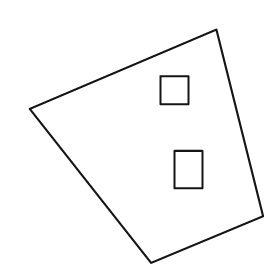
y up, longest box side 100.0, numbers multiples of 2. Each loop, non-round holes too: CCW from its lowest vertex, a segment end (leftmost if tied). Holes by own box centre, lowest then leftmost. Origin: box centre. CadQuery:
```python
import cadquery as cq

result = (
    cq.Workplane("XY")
    .moveTo(2.0, -50.0)
    .lineTo(50.0, -30.0)
    .lineTo(30.0, 50.0)
    .lineTo(-50.0, 16.0)
    .close()
    .moveTo(12.0, -18.0)
    .lineTo(24.0, -18.0)
    .lineTo(24.0, -2.0)
    .lineTo(12.0, -2.0)
    .close()
    .moveTo(6.0, 18.0)
    .lineTo(18.0, 18.0)
    .lineTo(18.0, 30.0)
    .lineTo(6.0, 30.0)
    .close()
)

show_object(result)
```